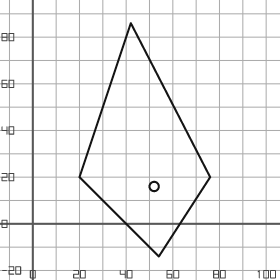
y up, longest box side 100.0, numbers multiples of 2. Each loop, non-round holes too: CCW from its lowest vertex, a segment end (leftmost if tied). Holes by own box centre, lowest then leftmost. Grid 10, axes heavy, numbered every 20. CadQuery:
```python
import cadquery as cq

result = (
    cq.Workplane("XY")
    .moveTo(54.0, -14.0)
    .lineTo(76.0, 20.0)
    .lineTo(42.0, 86.0)
    .lineTo(20.0, 20.0)
    .close()
    .moveTo(52.0, 16.0)
    .circle(2.0)
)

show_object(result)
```